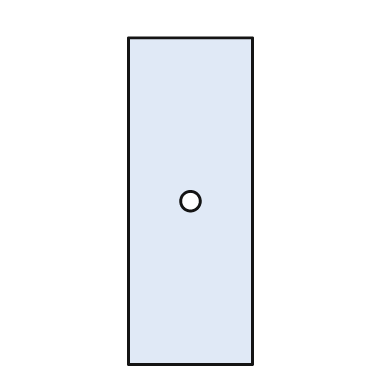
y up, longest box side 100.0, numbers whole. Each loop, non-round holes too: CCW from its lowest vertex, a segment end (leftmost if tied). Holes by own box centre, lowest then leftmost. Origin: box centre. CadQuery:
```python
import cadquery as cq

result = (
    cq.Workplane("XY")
    .moveTo(-19.0, -50.0)
    .lineTo(19.0, -50.0)
    .lineTo(19.0, 50.0)
    .lineTo(-19.0, 50.0)
    .close()
    .moveTo(0.0, 0.0)
    .circle(3.0)
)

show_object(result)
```